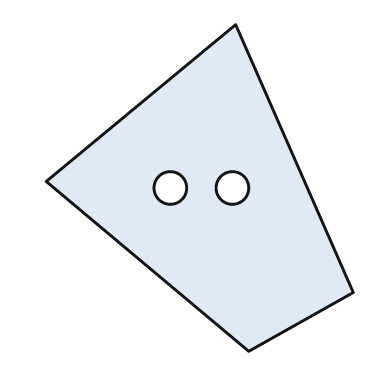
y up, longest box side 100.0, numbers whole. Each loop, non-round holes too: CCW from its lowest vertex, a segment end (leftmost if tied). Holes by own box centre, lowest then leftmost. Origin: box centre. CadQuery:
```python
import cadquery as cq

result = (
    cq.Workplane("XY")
    .moveTo(15.0, -50.0)
    .lineTo(47.0, -32.0)
    .lineTo(11.0, 50.0)
    .lineTo(-47.0, 2.0)
    .close()
    .moveTo(-9.0, 0.0)
    .circle(5.0)
    .moveTo(10.0, 0.0)
    .circle(5.0)
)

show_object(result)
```